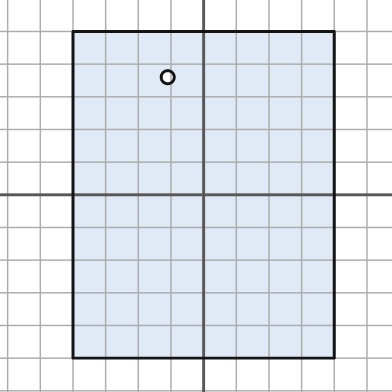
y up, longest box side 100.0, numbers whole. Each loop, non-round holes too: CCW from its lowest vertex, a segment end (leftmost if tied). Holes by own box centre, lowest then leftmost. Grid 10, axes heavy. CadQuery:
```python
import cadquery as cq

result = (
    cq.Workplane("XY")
    .moveTo(-40.0, -50.0)
    .lineTo(40.0, -50.0)
    .lineTo(40.0, 50.0)
    .lineTo(-40.0, 50.0)
    .close()
    .moveTo(-11.0, 36.0)
    .circle(2.0)
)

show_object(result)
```